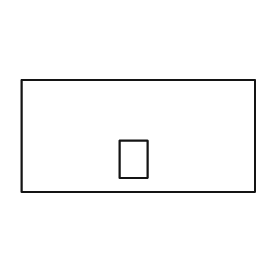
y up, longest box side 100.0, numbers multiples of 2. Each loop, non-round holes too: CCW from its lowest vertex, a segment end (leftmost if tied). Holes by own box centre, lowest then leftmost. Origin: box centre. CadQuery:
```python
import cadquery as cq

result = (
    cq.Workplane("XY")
    .moveTo(-50.0, -24.0)
    .lineTo(50.0, -24.0)
    .lineTo(50.0, 24.0)
    .lineTo(-50.0, 24.0)
    .close()
    .moveTo(-8.0, -18.0)
    .lineTo(4.0, -18.0)
    .lineTo(4.0, -2.0)
    .lineTo(-8.0, -2.0)
    .close()
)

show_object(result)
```